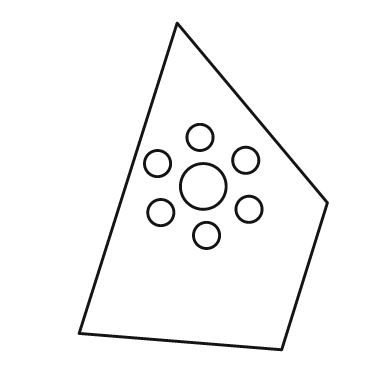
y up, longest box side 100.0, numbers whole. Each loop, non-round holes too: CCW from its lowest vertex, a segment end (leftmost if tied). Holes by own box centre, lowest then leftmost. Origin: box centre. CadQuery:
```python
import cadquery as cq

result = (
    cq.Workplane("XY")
    .moveTo(24.0, -50.0)
    .lineTo(38.0, -5.0)
    .lineTo(-8.0, 50.0)
    .lineTo(-38.0, -45.0)
    .close()
    .moveTo(1.0, -15.0)
    .circle(4.0)
    .moveTo(-13.0, -8.0)
    .circle(4.0)
    .moveTo(14.0, -7.0)
    .circle(4.0)
    .moveTo(0.0, 0.0)
    .circle(7.0)
    .moveTo(-14.0, 7.0)
    .circle(4.0)
    .moveTo(13.0, 8.0)
    .circle(4.0)
    .moveTo(-1.0, 15.0)
    .circle(4.0)
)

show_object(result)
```